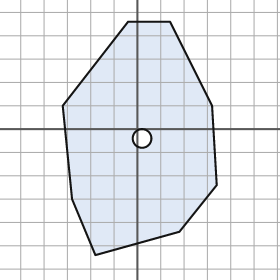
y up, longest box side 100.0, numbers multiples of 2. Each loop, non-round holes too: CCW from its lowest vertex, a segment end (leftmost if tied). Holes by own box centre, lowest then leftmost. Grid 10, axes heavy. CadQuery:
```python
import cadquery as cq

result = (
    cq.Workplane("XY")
    .moveTo(-18.0, -54.0)
    .lineTo(18.0, -44.0)
    .lineTo(34.0, -24.0)
    .lineTo(32.0, 10.0)
    .lineTo(14.0, 46.0)
    .lineTo(-4.0, 46.0)
    .lineTo(-32.0, 10.0)
    .lineTo(-28.0, -30.0)
    .close()
    .moveTo(2.0, -4.0)
    .circle(4.0)
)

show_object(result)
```